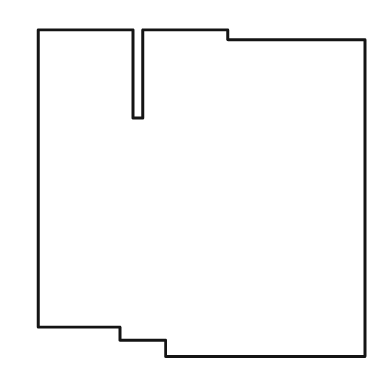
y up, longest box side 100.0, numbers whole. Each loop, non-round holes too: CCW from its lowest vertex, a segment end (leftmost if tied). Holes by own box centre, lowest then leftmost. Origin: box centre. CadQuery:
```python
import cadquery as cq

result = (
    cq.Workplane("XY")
    .moveTo(-11.0, -50.0)
    .lineTo(50.0, -50.0)
    .lineTo(50.0, 47.0)
    .lineTo(8.0, 47.0)
    .lineTo(8.0, 50.0)
    .lineTo(-18.0, 50.0)
    .lineTo(-18.0, 23.0)
    .lineTo(-21.0, 23.0)
    .lineTo(-21.0, 50.0)
    .lineTo(-50.0, 50.0)
    .lineTo(-50.0, -41.0)
    .lineTo(-25.0, -41.0)
    .lineTo(-25.0, -45.0)
    .lineTo(-11.0, -45.0)
    .close()
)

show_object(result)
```